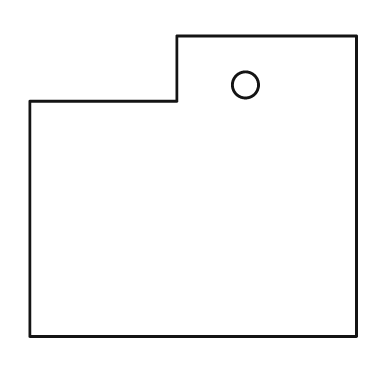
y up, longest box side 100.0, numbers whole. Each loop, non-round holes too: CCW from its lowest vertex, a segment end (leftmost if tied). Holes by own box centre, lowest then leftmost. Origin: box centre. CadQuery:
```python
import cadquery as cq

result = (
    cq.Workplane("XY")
    .moveTo(-50.0, -46.0)
    .lineTo(50.0, -46.0)
    .lineTo(50.0, 46.0)
    .lineTo(-5.0, 46.0)
    .lineTo(-5.0, 26.0)
    .lineTo(-50.0, 26.0)
    .close()
    .moveTo(16.0, 31.0)
    .circle(4.0)
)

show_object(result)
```